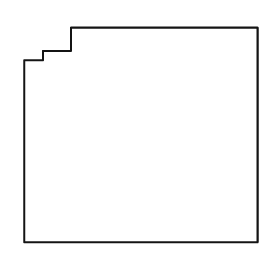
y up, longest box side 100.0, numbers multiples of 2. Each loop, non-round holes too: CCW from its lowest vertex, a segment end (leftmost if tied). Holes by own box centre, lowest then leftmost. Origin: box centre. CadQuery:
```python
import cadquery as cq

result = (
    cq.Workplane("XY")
    .moveTo(-50.0, -46.0)
    .lineTo(50.0, -46.0)
    .lineTo(50.0, 46.0)
    .lineTo(-30.0, 46.0)
    .lineTo(-30.0, 36.0)
    .lineTo(-42.0, 36.0)
    .lineTo(-42.0, 32.0)
    .lineTo(-50.0, 32.0)
    .close()
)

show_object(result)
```